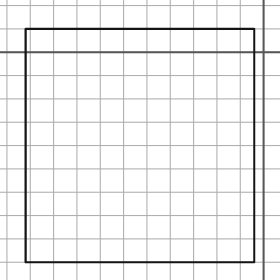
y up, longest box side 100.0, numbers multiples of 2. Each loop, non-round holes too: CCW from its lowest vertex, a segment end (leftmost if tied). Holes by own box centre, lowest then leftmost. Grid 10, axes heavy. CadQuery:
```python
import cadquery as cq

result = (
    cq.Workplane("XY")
    .moveTo(-102.0, -90.0)
    .lineTo(-4.0, -90.0)
    .lineTo(-4.0, 10.0)
    .lineTo(-102.0, 10.0)
    .close()
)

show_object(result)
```